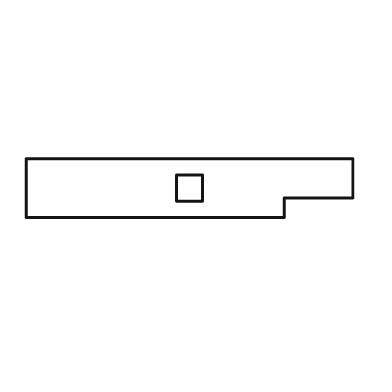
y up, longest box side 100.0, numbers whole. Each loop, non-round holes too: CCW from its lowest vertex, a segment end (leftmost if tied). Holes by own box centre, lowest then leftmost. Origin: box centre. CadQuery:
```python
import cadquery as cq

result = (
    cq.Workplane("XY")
    .moveTo(-50.0, -9.0)
    .lineTo(29.0, -9.0)
    .lineTo(29.0, -3.0)
    .lineTo(50.0, -3.0)
    .lineTo(50.0, 9.0)
    .lineTo(-50.0, 9.0)
    .close()
    .moveTo(-4.0, -4.0)
    .lineTo(4.0, -4.0)
    .lineTo(4.0, 4.0)
    .lineTo(-4.0, 4.0)
    .close()
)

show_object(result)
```